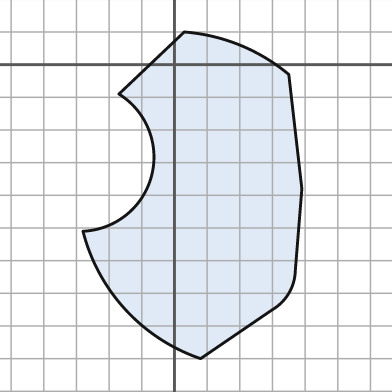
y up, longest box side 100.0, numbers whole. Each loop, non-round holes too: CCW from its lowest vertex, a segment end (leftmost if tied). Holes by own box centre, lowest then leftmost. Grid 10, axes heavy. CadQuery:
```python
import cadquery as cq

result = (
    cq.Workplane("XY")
    .moveTo(8.0, -90.0)
    .lineTo(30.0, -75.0)
    .threePointArc((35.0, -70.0), (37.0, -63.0))
    .lineTo(39.0, -38.0)
    .lineTo(35.0, -3.0)
    .threePointArc((20.0, 6.0), (3.0, 10.0))
    .lineTo(-17.0, -9.0)
    .threePointArc((-7.0, -34.0), (-28.0, -51.0))
    .threePointArc((-15.0, -75.0), (8.0, -90.0))
    .close()
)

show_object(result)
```